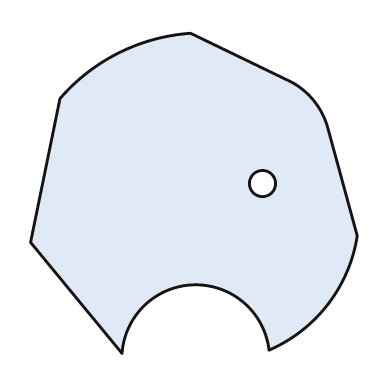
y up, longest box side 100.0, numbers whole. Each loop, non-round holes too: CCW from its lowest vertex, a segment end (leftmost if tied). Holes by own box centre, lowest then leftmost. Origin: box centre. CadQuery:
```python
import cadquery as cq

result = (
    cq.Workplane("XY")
    .moveTo(-22.0, -49.0)
    .threePointArc((0.0, -28.0), (23.0, -48.0))
    .threePointArc((41.0, -34.0), (50.0, -13.0))
    .lineTo(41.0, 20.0)
    .threePointArc((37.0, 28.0), (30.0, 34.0))
    .lineTo(-1.0, 49.0)
    .threePointArc((-23.0, 43.0), (-41.0, 29.0))
    .lineTo(-50.0, -15.0)
    .close()
    .moveTo(21.0, 3.0)
    .circle(4.0)
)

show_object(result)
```